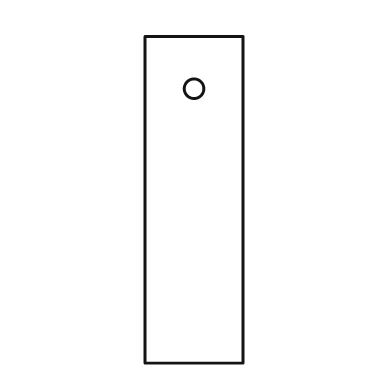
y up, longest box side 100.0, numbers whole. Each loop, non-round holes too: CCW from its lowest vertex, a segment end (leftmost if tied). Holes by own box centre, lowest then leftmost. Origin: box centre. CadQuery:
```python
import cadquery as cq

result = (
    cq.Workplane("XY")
    .moveTo(-15.0, -50.0)
    .lineTo(15.0, -50.0)
    .lineTo(15.0, 50.0)
    .lineTo(-15.0, 50.0)
    .close()
    .moveTo(0.0, 34.0)
    .circle(3.0)
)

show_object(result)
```